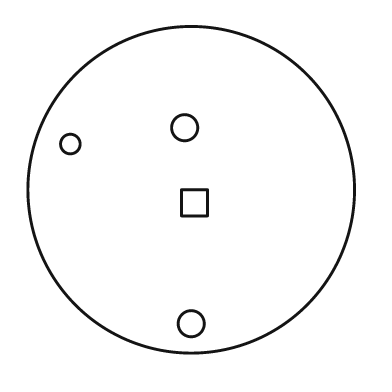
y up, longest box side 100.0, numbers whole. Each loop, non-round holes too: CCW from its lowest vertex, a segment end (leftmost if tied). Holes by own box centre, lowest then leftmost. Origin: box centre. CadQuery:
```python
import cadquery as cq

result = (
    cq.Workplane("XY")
    .moveTo(0.0, 0.0)
    .circle(50.0)
    .moveTo(0.0, -41.0)
    .circle(4.0)
    .moveTo(-3.0, -8.0)
    .lineTo(5.0, -8.0)
    .lineTo(5.0, 0.0)
    .lineTo(-3.0, 0.0)
    .close()
    .moveTo(-37.0, 14.0)
    .circle(3.0)
    .moveTo(-2.0, 19.0)
    .circle(4.0)
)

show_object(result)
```